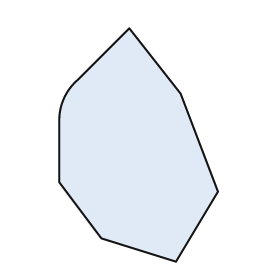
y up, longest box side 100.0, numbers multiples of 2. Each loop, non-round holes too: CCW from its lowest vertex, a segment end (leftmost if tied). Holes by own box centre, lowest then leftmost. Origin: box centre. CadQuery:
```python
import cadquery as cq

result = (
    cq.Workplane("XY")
    .moveTo(16.0, -50.0)
    .lineTo(34.0, -20.0)
    .lineTo(18.0, 22.0)
    .lineTo(-4.0, 50.0)
    .lineTo(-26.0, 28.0)
    .threePointArc((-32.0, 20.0), (-34.0, 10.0))
    .lineTo(-34.0, -16.0)
    .lineTo(-16.0, -40.0)
    .close()
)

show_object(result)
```